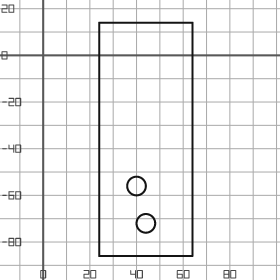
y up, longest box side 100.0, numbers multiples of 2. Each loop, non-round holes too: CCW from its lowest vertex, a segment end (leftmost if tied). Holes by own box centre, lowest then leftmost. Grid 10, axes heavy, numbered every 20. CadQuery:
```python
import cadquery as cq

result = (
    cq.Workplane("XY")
    .moveTo(24.0, -86.0)
    .lineTo(64.0, -86.0)
    .lineTo(64.0, 14.0)
    .lineTo(24.0, 14.0)
    .close()
    .moveTo(44.0, -72.0)
    .circle(4.0)
    .moveTo(40.0, -56.0)
    .circle(4.0)
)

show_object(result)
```